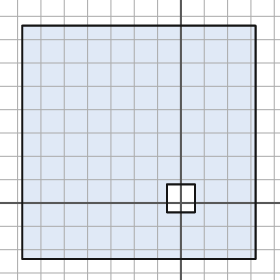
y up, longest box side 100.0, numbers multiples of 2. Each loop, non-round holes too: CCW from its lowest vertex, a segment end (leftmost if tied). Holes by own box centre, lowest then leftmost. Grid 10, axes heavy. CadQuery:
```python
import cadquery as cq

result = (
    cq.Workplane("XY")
    .moveTo(-68.0, -24.0)
    .lineTo(32.0, -24.0)
    .lineTo(32.0, 76.0)
    .lineTo(-68.0, 76.0)
    .close()
    .moveTo(-6.0, -4.0)
    .lineTo(6.0, -4.0)
    .lineTo(6.0, 8.0)
    .lineTo(-6.0, 8.0)
    .close()
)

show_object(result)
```